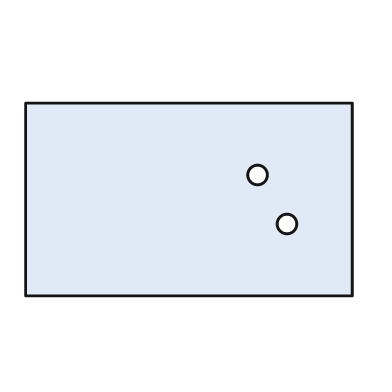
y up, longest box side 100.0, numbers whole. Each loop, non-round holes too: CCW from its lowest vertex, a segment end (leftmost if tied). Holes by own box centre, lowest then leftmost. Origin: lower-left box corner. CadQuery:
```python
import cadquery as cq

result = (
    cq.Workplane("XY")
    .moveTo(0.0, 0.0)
    .lineTo(100.0, 0.0)
    .lineTo(100.0, 59.0)
    .lineTo(0.0, 59.0)
    .close()
    .moveTo(80.0, 22.0)
    .circle(3.0)
    .moveTo(71.0, 37.0)
    .circle(3.0)
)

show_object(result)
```